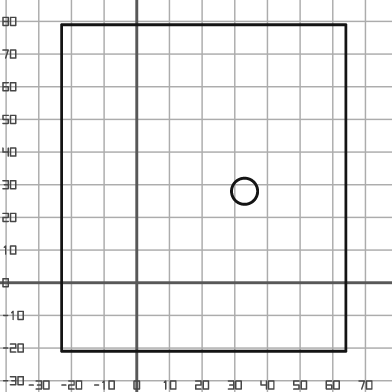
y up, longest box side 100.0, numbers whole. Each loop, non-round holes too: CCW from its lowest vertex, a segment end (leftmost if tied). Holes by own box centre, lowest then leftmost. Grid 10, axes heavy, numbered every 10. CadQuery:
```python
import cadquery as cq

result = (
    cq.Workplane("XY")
    .moveTo(-23.0, -21.0)
    .lineTo(64.0, -21.0)
    .lineTo(64.0, 79.0)
    .lineTo(-23.0, 79.0)
    .close()
    .moveTo(33.0, 28.0)
    .circle(4.0)
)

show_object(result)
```